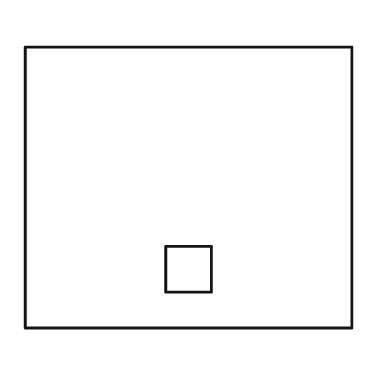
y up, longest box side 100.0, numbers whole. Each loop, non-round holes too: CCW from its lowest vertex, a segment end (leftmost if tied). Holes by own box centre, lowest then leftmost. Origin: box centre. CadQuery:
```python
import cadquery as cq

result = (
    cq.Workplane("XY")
    .moveTo(-50.0, -43.0)
    .lineTo(50.0, -43.0)
    .lineTo(50.0, 43.0)
    .lineTo(-50.0, 43.0)
    .close()
    .moveTo(-7.0, -32.0)
    .lineTo(7.0, -32.0)
    .lineTo(7.0, -18.0)
    .lineTo(-7.0, -18.0)
    .close()
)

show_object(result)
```